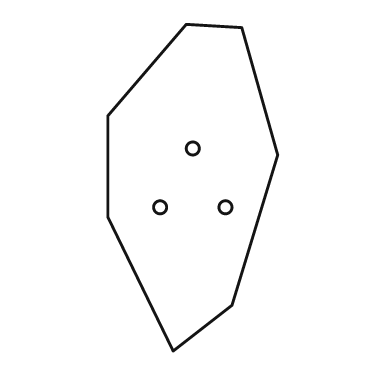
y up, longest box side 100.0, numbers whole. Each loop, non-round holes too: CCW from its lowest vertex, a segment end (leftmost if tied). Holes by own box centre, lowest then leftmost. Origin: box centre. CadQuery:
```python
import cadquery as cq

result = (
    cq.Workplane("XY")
    .moveTo(-6.0, -50.0)
    .lineTo(12.0, -36.0)
    .lineTo(26.0, 10.0)
    .lineTo(15.0, 49.0)
    .lineTo(-2.0, 50.0)
    .lineTo(-26.0, 22.0)
    .lineTo(-26.0, -9.0)
    .close()
    .moveTo(-10.0, -6.0)
    .circle(2.0)
    .moveTo(10.0, -6.0)
    .circle(2.0)
    .moveTo(0.0, 12.0)
    .circle(2.0)
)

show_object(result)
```